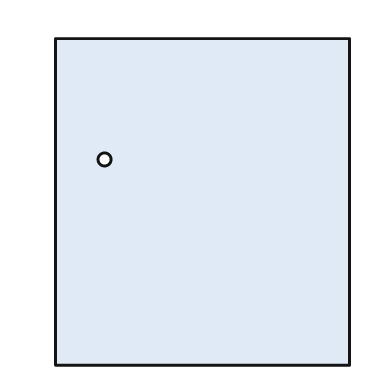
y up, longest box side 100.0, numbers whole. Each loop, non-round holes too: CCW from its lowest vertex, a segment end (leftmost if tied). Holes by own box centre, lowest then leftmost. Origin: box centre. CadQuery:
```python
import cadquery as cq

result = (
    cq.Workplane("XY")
    .moveTo(-45.0, -50.0)
    .lineTo(45.0, -50.0)
    .lineTo(45.0, 50.0)
    .lineTo(-45.0, 50.0)
    .close()
    .moveTo(-30.0, 13.0)
    .circle(2.0)
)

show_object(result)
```